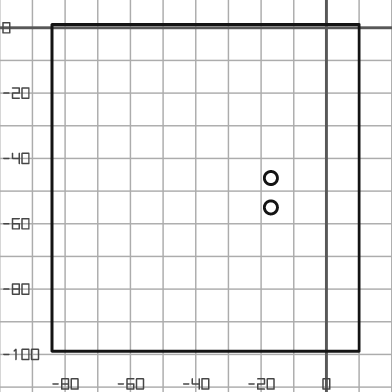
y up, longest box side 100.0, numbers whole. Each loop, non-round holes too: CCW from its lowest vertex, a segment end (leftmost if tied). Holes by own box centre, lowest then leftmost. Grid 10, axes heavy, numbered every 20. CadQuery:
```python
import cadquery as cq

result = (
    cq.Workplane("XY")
    .moveTo(-84.0, -99.0)
    .lineTo(10.0, -99.0)
    .lineTo(10.0, 1.0)
    .lineTo(-84.0, 1.0)
    .close()
    .moveTo(-17.0, -55.0)
    .circle(2.0)
    .moveTo(-17.0, -46.0)
    .circle(2.0)
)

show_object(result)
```